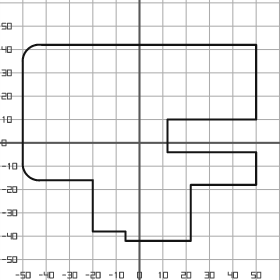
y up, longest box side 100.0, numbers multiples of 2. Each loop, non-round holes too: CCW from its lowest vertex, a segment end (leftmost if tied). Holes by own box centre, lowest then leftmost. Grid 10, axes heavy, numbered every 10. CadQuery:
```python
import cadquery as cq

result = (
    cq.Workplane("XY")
    .moveTo(-6.0, -42.0)
    .lineTo(22.0, -42.0)
    .lineTo(22.0, -18.0)
    .lineTo(50.0, -18.0)
    .lineTo(50.0, -4.0)
    .lineTo(12.0, -4.0)
    .lineTo(12.0, 10.0)
    .lineTo(50.0, 10.0)
    .lineTo(50.0, 42.0)
    .lineTo(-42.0, 42.0)
    .threePointArc((-48.0, 40.0), (-50.0, 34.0))
    .lineTo(-50.0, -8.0)
    .threePointArc((-48.0, -14.0), (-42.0, -16.0))
    .lineTo(-20.0, -16.0)
    .lineTo(-20.0, -38.0)
    .lineTo(-6.0, -38.0)
    .close()
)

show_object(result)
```